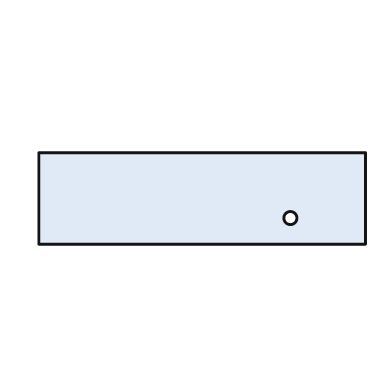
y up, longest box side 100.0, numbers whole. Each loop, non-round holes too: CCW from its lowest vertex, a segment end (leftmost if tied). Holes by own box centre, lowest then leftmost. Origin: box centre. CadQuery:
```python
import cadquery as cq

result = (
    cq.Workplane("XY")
    .moveTo(-50.0, -14.0)
    .lineTo(50.0, -14.0)
    .lineTo(50.0, 14.0)
    .lineTo(-50.0, 14.0)
    .close()
    .moveTo(27.0, -6.0)
    .circle(2.0)
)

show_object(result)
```